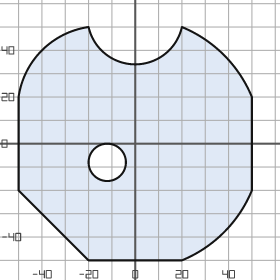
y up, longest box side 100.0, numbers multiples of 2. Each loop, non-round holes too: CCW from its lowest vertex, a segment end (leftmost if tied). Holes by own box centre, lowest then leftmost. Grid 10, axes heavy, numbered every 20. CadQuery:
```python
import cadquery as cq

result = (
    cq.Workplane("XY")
    .moveTo(-20.0, -50.0)
    .lineTo(20.0, -50.0)
    .threePointArc((38.0, -38.0), (50.0, -20.0))
    .lineTo(50.0, 20.0)
    .threePointArc((38.0, 38.0), (20.0, 50.0))
    .threePointArc((0.0, 34.0), (-20.0, 50.0))
    .threePointArc((-40.0, 40.0), (-50.0, 20.0))
    .lineTo(-50.0, -20.0)
    .close()
    .moveTo(-12.0, -8.0)
    .circle(8.0)
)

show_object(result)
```